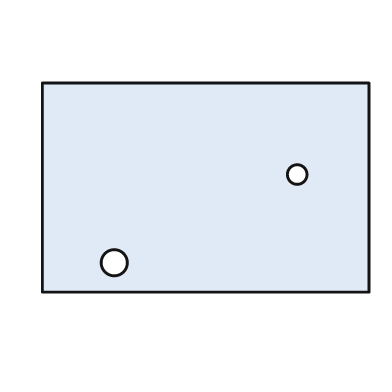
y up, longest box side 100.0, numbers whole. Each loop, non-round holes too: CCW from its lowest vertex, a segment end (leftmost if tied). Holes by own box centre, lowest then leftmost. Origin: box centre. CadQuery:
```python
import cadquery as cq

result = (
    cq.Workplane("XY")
    .moveTo(-50.0, -32.0)
    .lineTo(50.0, -32.0)
    .lineTo(50.0, 32.0)
    .lineTo(-50.0, 32.0)
    .close()
    .moveTo(-28.0, -23.0)
    .circle(4.0)
    .moveTo(28.0, 4.0)
    .circle(3.0)
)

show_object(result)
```